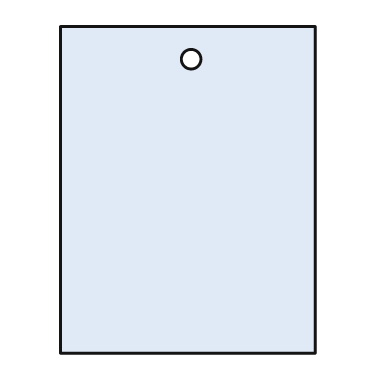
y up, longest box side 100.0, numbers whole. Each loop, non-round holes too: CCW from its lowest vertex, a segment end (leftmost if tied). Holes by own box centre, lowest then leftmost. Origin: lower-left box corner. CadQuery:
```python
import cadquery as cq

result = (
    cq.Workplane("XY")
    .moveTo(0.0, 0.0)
    .lineTo(78.0, 0.0)
    .lineTo(78.0, 100.0)
    .lineTo(0.0, 100.0)
    .close()
    .moveTo(40.0, 90.0)
    .circle(3.0)
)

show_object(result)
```